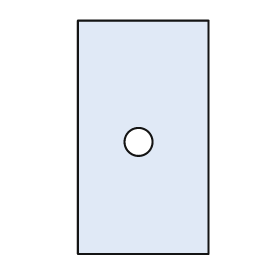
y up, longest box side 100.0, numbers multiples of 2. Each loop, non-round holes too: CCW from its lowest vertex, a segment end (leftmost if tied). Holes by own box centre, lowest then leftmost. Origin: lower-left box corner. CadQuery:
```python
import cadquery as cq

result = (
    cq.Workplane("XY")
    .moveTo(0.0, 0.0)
    .lineTo(56.0, 0.0)
    .lineTo(56.0, 100.0)
    .lineTo(0.0, 100.0)
    .close()
    .moveTo(26.0, 48.0)
    .circle(6.0)
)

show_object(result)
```